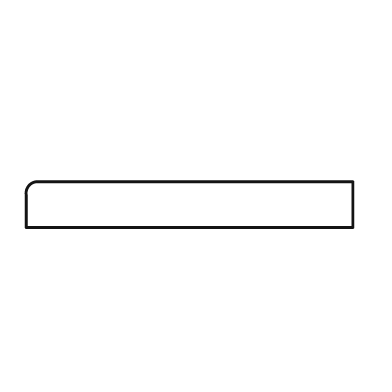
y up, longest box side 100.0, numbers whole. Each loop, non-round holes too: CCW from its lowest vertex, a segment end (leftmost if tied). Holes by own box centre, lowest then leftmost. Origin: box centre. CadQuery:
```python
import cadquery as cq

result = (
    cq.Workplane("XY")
    .moveTo(-50.0, -7.0)
    .lineTo(50.0, -7.0)
    .lineTo(50.0, 7.0)
    .lineTo(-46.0, 7.0)
    .threePointArc((-49.0, 6.0), (-50.0, 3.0))
    .close()
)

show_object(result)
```